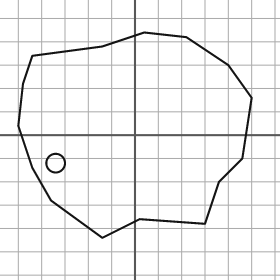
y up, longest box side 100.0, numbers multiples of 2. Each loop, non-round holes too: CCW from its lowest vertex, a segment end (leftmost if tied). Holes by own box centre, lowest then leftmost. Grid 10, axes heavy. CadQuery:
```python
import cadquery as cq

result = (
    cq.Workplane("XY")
    .moveTo(-14.0, -44.0)
    .lineTo(2.0, -36.0)
    .lineTo(30.0, -38.0)
    .lineTo(36.0, -20.0)
    .lineTo(46.0, -10.0)
    .lineTo(50.0, 16.0)
    .lineTo(40.0, 30.0)
    .lineTo(22.0, 42.0)
    .lineTo(4.0, 44.0)
    .lineTo(-14.0, 38.0)
    .lineTo(-44.0, 34.0)
    .lineTo(-48.0, 22.0)
    .lineTo(-50.0, 4.0)
    .lineTo(-44.0, -14.0)
    .lineTo(-36.0, -28.0)
    .close()
    .moveTo(-34.0, -12.0)
    .circle(4.0)
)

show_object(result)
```